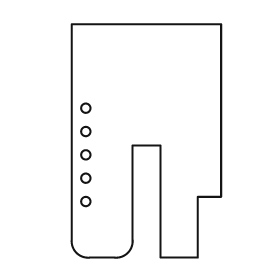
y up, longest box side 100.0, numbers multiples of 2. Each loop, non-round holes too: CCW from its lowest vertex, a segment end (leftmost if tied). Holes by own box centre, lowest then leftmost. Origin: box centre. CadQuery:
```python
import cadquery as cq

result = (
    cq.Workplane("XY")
    .moveTo(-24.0, -50.0)
    .lineTo(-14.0, -50.0)
    .threePointArc((-8.0, -48.0), (-6.0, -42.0))
    .lineTo(-6.0, -2.0)
    .lineTo(6.0, -2.0)
    .lineTo(6.0, -50.0)
    .lineTo(22.0, -50.0)
    .lineTo(22.0, -24.0)
    .lineTo(32.0, -24.0)
    .lineTo(32.0, 50.0)
    .lineTo(-32.0, 50.0)
    .lineTo(-32.0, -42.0)
    .threePointArc((-30.0, -48.0), (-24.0, -50.0))
    .close()
    .moveTo(-26.0, -26.0)
    .circle(2.0)
    .moveTo(-26.0, -16.0)
    .circle(2.0)
    .moveTo(-26.0, -6.0)
    .circle(2.0)
    .moveTo(-26.0, 4.0)
    .circle(2.0)
    .moveTo(-26.0, 14.0)
    .circle(2.0)
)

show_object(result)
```